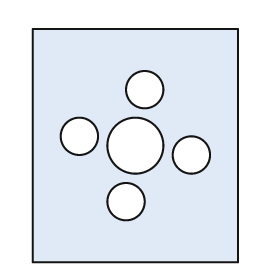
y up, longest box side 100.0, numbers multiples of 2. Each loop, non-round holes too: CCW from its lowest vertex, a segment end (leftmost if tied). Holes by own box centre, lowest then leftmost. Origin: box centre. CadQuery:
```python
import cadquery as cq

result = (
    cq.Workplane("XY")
    .moveTo(-44.0, -50.0)
    .lineTo(44.0, -50.0)
    .lineTo(44.0, 50.0)
    .lineTo(-44.0, 50.0)
    .close()
    .moveTo(-4.0, -24.0)
    .circle(8.0)
    .moveTo(24.0, -4.0)
    .circle(8.0)
    .moveTo(0.0, 0.0)
    .circle(12.0)
    .moveTo(-24.0, 4.0)
    .circle(8.0)
    .moveTo(4.0, 24.0)
    .circle(8.0)
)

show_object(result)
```